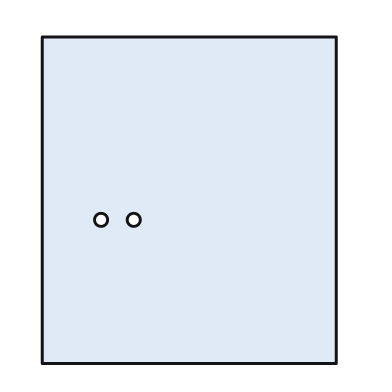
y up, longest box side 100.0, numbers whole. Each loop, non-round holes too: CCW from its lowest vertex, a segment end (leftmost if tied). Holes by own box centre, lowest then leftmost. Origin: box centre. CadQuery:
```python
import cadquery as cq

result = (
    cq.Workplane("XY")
    .moveTo(-45.0, -50.0)
    .lineTo(45.0, -50.0)
    .lineTo(45.0, 50.0)
    .lineTo(-45.0, 50.0)
    .close()
    .moveTo(-27.0, -6.0)
    .circle(2.0)
    .moveTo(-17.0, -6.0)
    .circle(2.0)
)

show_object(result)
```